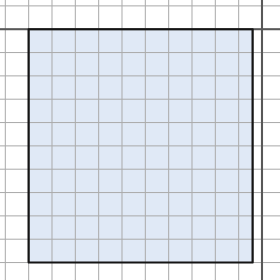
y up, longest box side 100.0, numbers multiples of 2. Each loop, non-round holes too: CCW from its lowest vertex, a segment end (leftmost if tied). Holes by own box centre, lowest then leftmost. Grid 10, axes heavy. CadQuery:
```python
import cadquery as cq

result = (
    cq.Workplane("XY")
    .moveTo(-100.0, -100.0)
    .lineTo(-4.0, -100.0)
    .lineTo(-4.0, 0.0)
    .lineTo(-100.0, 0.0)
    .close()
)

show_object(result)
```